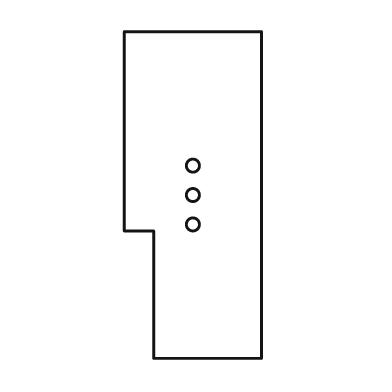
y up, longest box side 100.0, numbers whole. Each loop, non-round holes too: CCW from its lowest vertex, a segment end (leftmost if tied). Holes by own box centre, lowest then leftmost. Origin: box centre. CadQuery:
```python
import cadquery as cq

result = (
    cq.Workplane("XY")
    .moveTo(-12.0, -50.0)
    .lineTo(21.0, -50.0)
    .lineTo(21.0, 50.0)
    .lineTo(-21.0, 50.0)
    .lineTo(-21.0, -11.0)
    .lineTo(-12.0, -11.0)
    .close()
    .moveTo(0.0, -9.0)
    .circle(2.0)
    .moveTo(0.0, 0.0)
    .circle(2.0)
    .moveTo(0.0, 9.0)
    .circle(2.0)
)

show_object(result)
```